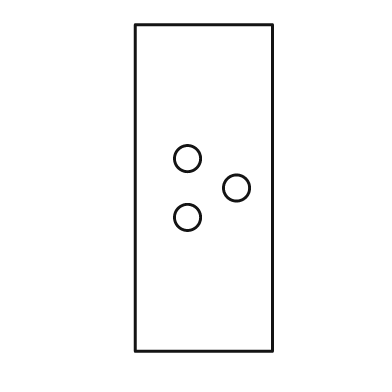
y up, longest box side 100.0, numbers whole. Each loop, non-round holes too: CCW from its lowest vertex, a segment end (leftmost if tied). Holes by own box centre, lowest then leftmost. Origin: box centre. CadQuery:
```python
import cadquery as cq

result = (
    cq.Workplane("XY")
    .moveTo(-21.0, -50.0)
    .lineTo(21.0, -50.0)
    .lineTo(21.0, 50.0)
    .lineTo(-21.0, 50.0)
    .close()
    .moveTo(-5.0, -9.0)
    .circle(4.0)
    .moveTo(10.0, 0.0)
    .circle(4.0)
    .moveTo(-5.0, 9.0)
    .circle(4.0)
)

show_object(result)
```